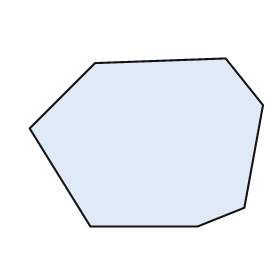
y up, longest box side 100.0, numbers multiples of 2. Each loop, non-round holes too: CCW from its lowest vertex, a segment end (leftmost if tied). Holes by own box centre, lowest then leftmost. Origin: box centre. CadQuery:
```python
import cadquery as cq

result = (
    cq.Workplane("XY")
    .moveTo(-24.0, -36.0)
    .lineTo(22.0, -36.0)
    .lineTo(42.0, -28.0)
    .lineTo(50.0, 16.0)
    .lineTo(34.0, 36.0)
    .lineTo(-22.0, 34.0)
    .lineTo(-50.0, 6.0)
    .close()
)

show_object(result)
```